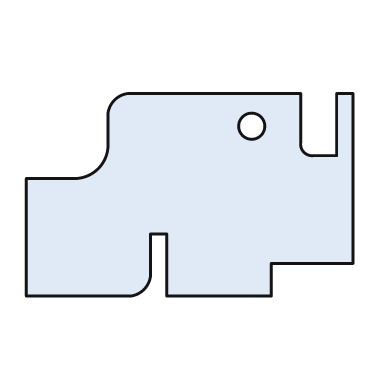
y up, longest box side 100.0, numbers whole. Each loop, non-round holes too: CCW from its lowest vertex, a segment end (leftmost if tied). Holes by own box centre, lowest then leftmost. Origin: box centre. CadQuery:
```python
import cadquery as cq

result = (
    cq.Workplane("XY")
    .moveTo(-50.0, -31.0)
    .lineTo(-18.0, -31.0)
    .threePointArc((-14.0, -29.0), (-12.0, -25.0))
    .lineTo(-12.0, -12.0)
    .lineTo(-7.0, -12.0)
    .lineTo(-7.0, -31.0)
    .lineTo(25.0, -31.0)
    .lineTo(25.0, -21.0)
    .lineTo(50.0, -21.0)
    .lineTo(50.0, 31.0)
    .lineTo(45.0, 31.0)
    .lineTo(45.0, 12.0)
    .lineTo(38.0, 12.0)
    .threePointArc((35.0, 13.0), (34.0, 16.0))
    .lineTo(34.0, 31.0)
    .lineTo(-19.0, 31.0)
    .threePointArc((-23.0, 29.0), (-25.0, 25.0))
    .lineTo(-25.0, 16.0)
    .threePointArc((-28.0, 8.0), (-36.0, 5.0))
    .lineTo(-50.0, 5.0)
    .close()
    .moveTo(19.0, 21.0)
    .circle(4.0)
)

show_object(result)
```